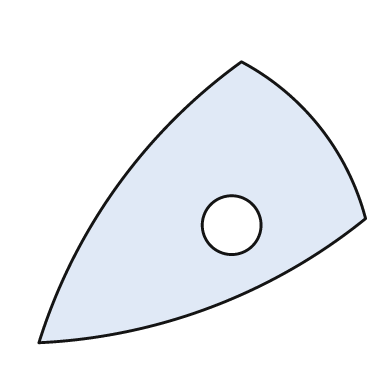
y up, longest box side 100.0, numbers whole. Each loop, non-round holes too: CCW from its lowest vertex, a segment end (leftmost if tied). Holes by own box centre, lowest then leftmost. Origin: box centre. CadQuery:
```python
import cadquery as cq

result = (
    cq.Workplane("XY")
    .moveTo(-50.0, -43.0)
    .threePointArc((3.0, -32.0), (50.0, -5.0))
    .threePointArc((36.0, 23.0), (12.0, 43.0))
    .threePointArc((-26.0, 5.0), (-50.0, -43.0))
    .close()
    .moveTo(9.0, -7.0)
    .circle(9.0)
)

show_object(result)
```